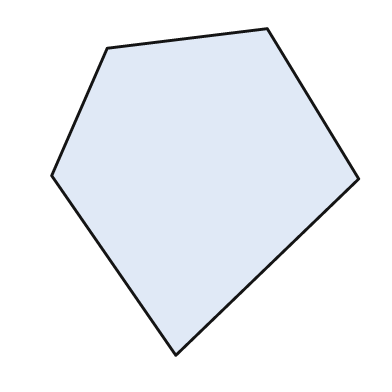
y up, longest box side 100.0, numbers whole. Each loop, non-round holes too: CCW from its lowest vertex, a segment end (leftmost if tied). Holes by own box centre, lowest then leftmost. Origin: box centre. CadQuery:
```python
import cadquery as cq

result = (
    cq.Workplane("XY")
    .moveTo(-9.0, -50.0)
    .lineTo(47.0, 4.0)
    .lineTo(19.0, 50.0)
    .lineTo(-30.0, 44.0)
    .lineTo(-47.0, 5.0)
    .close()
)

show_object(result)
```